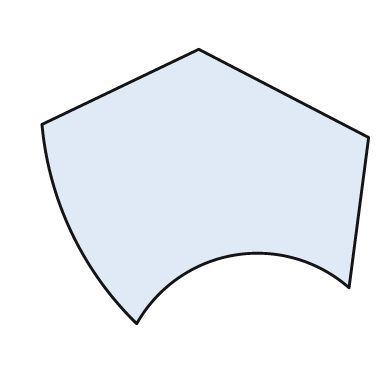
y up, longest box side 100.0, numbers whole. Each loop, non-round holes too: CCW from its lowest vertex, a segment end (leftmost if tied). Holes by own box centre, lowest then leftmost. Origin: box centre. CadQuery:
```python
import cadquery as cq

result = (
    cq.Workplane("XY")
    .moveTo(-21.0, -42.0)
    .threePointArc((9.0, -21.0), (44.0, -31.0))
    .lineTo(50.0, 15.0)
    .lineTo(-2.0, 42.0)
    .lineTo(-50.0, 19.0)
    .threePointArc((-41.0, -14.0), (-21.0, -42.0))
    .close()
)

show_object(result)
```